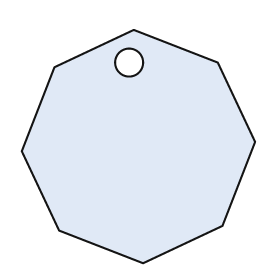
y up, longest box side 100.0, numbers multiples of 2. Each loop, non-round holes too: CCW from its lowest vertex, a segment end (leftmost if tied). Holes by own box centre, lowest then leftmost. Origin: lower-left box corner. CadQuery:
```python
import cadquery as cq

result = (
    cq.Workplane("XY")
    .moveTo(52.0, 0.0)
    .lineTo(86.0, 16.0)
    .lineTo(100.0, 52.0)
    .lineTo(84.0, 86.0)
    .lineTo(48.0, 100.0)
    .lineTo(14.0, 84.0)
    .lineTo(0.0, 48.0)
    .lineTo(16.0, 14.0)
    .close()
    .moveTo(46.0, 86.0)
    .circle(6.0)
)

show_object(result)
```